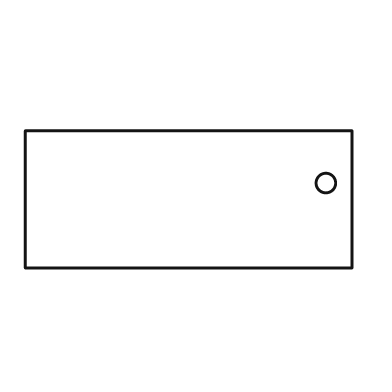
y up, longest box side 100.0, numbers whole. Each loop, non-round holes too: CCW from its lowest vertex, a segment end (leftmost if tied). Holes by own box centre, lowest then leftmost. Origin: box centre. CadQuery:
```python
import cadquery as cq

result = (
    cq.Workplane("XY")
    .moveTo(-50.0, -21.0)
    .lineTo(50.0, -21.0)
    .lineTo(50.0, 21.0)
    .lineTo(-50.0, 21.0)
    .close()
    .moveTo(42.0, 5.0)
    .circle(3.0)
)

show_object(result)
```